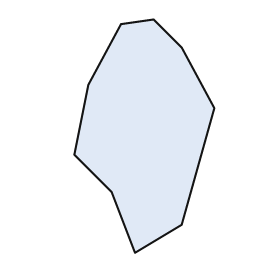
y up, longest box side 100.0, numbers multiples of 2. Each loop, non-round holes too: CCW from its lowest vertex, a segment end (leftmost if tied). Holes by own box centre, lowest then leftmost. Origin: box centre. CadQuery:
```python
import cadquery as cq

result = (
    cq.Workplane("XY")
    .moveTo(-4.0, -50.0)
    .lineTo(16.0, -38.0)
    .lineTo(30.0, 12.0)
    .lineTo(16.0, 38.0)
    .lineTo(4.0, 50.0)
    .lineTo(-10.0, 48.0)
    .lineTo(-24.0, 22.0)
    .lineTo(-30.0, -8.0)
    .lineTo(-14.0, -24.0)
    .close()
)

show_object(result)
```